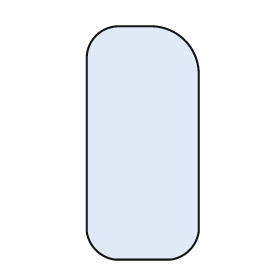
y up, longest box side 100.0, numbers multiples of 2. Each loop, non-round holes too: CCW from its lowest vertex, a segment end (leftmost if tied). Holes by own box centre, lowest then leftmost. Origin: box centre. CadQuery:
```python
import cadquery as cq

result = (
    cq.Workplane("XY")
    .moveTo(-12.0, -50.0)
    .lineTo(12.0, -50.0)
    .threePointArc((20.0, -46.0), (24.0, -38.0))
    .lineTo(24.0, 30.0)
    .threePointArc((18.0, 44.0), (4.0, 50.0))
    .lineTo(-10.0, 50.0)
    .threePointArc((-20.0, 46.0), (-24.0, 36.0))
    .lineTo(-24.0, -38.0)
    .threePointArc((-20.0, -46.0), (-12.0, -50.0))
    .close()
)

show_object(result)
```